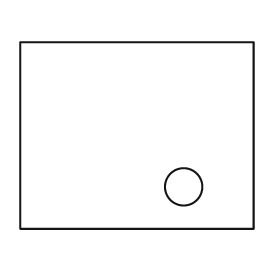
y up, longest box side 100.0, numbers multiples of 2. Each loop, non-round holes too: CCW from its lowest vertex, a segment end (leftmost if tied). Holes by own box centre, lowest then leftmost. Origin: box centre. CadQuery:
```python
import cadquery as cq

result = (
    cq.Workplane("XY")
    .moveTo(-50.0, -40.0)
    .lineTo(50.0, -40.0)
    .lineTo(50.0, 40.0)
    .lineTo(-50.0, 40.0)
    .close()
    .moveTo(20.0, -22.0)
    .circle(8.0)
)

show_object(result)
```